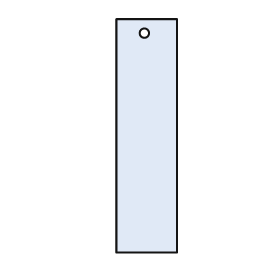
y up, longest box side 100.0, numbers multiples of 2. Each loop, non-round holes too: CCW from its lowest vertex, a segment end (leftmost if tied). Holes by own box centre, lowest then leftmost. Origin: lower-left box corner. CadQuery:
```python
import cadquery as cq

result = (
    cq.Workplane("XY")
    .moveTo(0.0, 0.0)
    .lineTo(26.0, 0.0)
    .lineTo(26.0, 100.0)
    .lineTo(0.0, 100.0)
    .close()
    .moveTo(12.0, 94.0)
    .circle(2.0)
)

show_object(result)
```